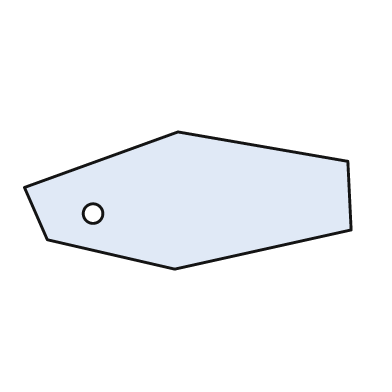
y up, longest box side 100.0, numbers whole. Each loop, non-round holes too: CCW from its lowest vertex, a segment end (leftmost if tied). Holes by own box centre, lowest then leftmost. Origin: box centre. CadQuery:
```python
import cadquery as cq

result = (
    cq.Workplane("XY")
    .moveTo(-4.0, -21.0)
    .lineTo(50.0, -9.0)
    .lineTo(49.0, 12.0)
    .lineTo(-3.0, 21.0)
    .lineTo(-50.0, 4.0)
    .lineTo(-43.0, -12.0)
    .close()
    .moveTo(-29.0, -4.0)
    .circle(3.0)
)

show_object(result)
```